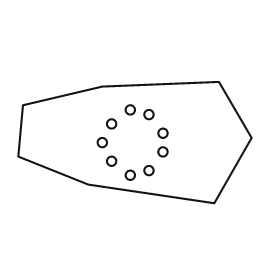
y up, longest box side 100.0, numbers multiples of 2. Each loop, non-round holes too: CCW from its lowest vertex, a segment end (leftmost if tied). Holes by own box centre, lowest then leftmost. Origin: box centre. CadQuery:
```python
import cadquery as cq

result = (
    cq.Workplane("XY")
    .moveTo(34.0, -26.0)
    .lineTo(50.0, 2.0)
    .lineTo(36.0, 26.0)
    .lineTo(-14.0, 24.0)
    .lineTo(-48.0, 16.0)
    .lineTo(-50.0, -6.0)
    .lineTo(-20.0, -18.0)
    .close()
    .moveTo(-2.0, -14.0)
    .circle(2.0)
    .moveTo(6.0, -12.0)
    .circle(2.0)
    .moveTo(-10.0, -8.0)
    .circle(2.0)
    .moveTo(12.0, -4.0)
    .circle(2.0)
    .moveTo(-14.0, 0.0)
    .circle(2.0)
    .moveTo(12.0, 4.0)
    .circle(2.0)
    .moveTo(-10.0, 8.0)
    .circle(2.0)
    .moveTo(6.0, 12.0)
    .circle(2.0)
    .moveTo(-2.0, 14.0)
    .circle(2.0)
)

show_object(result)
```